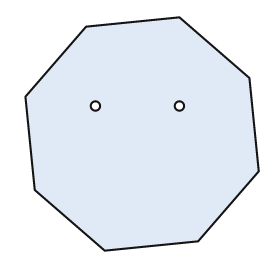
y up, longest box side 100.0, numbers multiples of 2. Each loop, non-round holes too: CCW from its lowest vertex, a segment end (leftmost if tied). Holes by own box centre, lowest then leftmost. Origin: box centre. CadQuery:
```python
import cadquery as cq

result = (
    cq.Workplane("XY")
    .moveTo(-16.0, -50.0)
    .lineTo(24.0, -46.0)
    .lineTo(50.0, -16.0)
    .lineTo(46.0, 24.0)
    .lineTo(16.0, 50.0)
    .lineTo(-24.0, 46.0)
    .lineTo(-50.0, 16.0)
    .lineTo(-46.0, -24.0)
    .close()
    .moveTo(-20.0, 12.0)
    .circle(2.0)
    .moveTo(16.0, 12.0)
    .circle(2.0)
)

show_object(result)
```